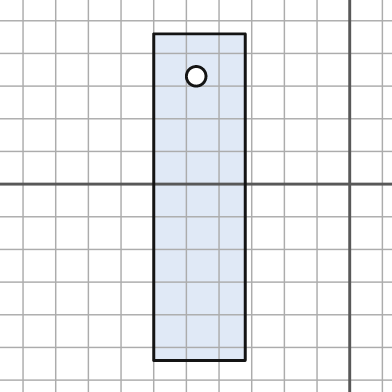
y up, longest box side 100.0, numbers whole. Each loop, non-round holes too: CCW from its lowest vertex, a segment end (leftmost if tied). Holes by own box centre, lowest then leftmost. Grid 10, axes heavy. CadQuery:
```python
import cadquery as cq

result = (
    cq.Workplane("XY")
    .moveTo(-60.0, -54.0)
    .lineTo(-32.0, -54.0)
    .lineTo(-32.0, 46.0)
    .lineTo(-60.0, 46.0)
    .close()
    .moveTo(-47.0, 33.0)
    .circle(3.0)
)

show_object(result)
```